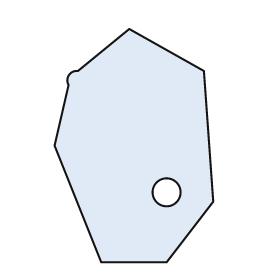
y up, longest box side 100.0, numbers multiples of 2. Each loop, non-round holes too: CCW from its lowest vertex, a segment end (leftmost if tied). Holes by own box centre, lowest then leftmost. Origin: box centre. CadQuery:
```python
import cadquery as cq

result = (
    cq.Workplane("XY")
    .moveTo(-14.0, -50.0)
    .lineTo(14.0, -50.0)
    .lineTo(34.0, -24.0)
    .lineTo(30.0, 32.0)
    .lineTo(-2.0, 50.0)
    .lineTo(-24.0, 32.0)
    .threePointArc((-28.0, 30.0), (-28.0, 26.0))
    .lineTo(-34.0, 0.0)
    .close()
    .moveTo(14.0, -20.0)
    .circle(6.0)
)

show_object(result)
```